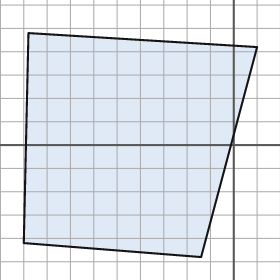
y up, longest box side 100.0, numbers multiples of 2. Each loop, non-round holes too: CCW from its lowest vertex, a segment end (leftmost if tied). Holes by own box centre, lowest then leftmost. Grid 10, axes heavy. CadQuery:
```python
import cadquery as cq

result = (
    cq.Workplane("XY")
    .moveTo(-14.0, -48.0)
    .lineTo(10.0, 42.0)
    .lineTo(-88.0, 48.0)
    .lineTo(-90.0, -42.0)
    .close()
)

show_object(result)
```